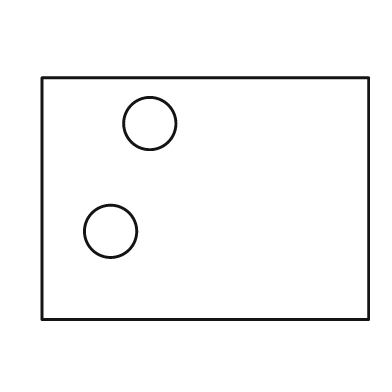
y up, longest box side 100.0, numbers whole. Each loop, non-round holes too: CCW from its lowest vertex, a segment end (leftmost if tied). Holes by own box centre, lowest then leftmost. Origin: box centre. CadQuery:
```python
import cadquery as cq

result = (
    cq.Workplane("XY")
    .moveTo(-50.0, -37.0)
    .lineTo(50.0, -37.0)
    .lineTo(50.0, 37.0)
    .lineTo(-50.0, 37.0)
    .close()
    .moveTo(-29.0, -10.0)
    .circle(8.0)
    .moveTo(-17.0, 23.0)
    .circle(8.0)
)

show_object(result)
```